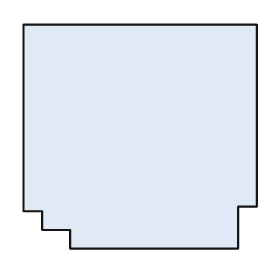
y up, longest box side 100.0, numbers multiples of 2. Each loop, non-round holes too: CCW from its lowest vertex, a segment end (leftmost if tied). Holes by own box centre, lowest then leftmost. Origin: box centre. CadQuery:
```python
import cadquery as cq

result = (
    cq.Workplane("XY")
    .moveTo(-30.0, -48.0)
    .lineTo(42.0, -48.0)
    .lineTo(42.0, -30.0)
    .lineTo(50.0, -30.0)
    .lineTo(50.0, 48.0)
    .lineTo(-50.0, 48.0)
    .lineTo(-50.0, -32.0)
    .lineTo(-42.0, -32.0)
    .lineTo(-42.0, -40.0)
    .lineTo(-30.0, -40.0)
    .close()
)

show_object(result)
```